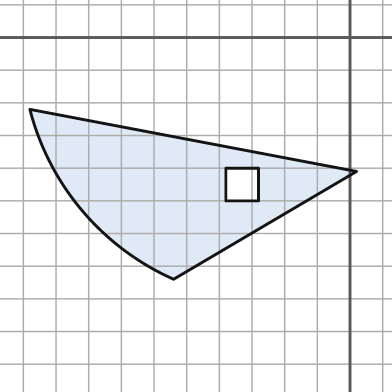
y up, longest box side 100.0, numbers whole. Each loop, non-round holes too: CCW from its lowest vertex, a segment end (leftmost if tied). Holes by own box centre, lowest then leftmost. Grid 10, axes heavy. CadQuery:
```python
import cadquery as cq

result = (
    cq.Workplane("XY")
    .moveTo(-54.0, -74.0)
    .lineTo(2.0, -41.0)
    .lineTo(-98.0, -22.0)
    .threePointArc((-82.0, -53.0), (-54.0, -74.0))
    .close()
    .moveTo(-38.0, -50.0)
    .lineTo(-28.0, -50.0)
    .lineTo(-28.0, -40.0)
    .lineTo(-38.0, -40.0)
    .close()
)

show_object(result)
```